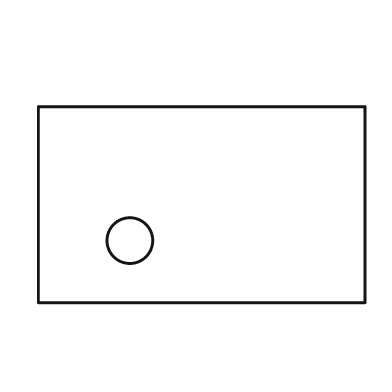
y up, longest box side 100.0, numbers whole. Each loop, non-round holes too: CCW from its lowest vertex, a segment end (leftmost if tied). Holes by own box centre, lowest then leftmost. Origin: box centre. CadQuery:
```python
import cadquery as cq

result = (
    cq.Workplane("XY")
    .moveTo(-50.0, -30.0)
    .lineTo(50.0, -30.0)
    .lineTo(50.0, 30.0)
    .lineTo(-50.0, 30.0)
    .close()
    .moveTo(-22.0, -11.0)
    .circle(7.0)
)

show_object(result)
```